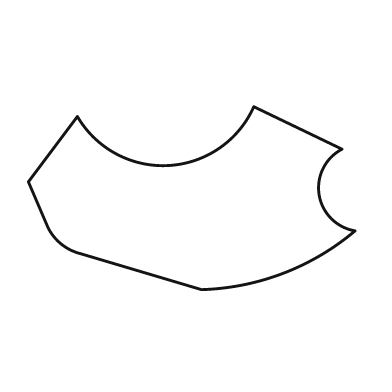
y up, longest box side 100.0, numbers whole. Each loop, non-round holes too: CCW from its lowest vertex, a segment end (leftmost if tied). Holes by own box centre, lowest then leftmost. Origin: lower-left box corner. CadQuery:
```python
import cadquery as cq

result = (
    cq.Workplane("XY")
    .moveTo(53.0, 0.0)
    .threePointArc((78.0, 5.0), (100.0, 18.0))
    .threePointArc((89.0, 29.0), (96.0, 43.0))
    .lineTo(69.0, 56.0)
    .threePointArc((43.0, 38.0), (15.0, 53.0))
    .lineTo(0.0, 33.0)
    .lineTo(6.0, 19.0)
    .threePointArc((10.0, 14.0), (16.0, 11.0))
    .close()
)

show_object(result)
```